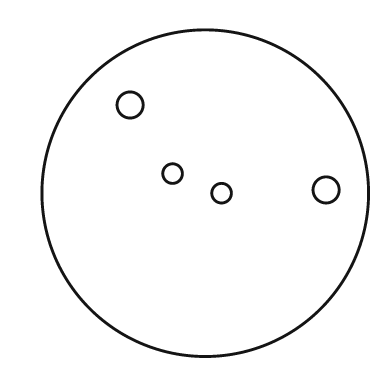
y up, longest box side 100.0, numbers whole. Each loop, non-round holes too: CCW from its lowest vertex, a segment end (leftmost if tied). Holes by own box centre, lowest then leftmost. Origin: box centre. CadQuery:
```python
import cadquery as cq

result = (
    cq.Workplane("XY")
    .moveTo(0.0, 0.0)
    .circle(50.0)
    .moveTo(5.0, 0.0)
    .circle(3.0)
    .moveTo(37.0, 1.0)
    .circle(4.0)
    .moveTo(-10.0, 6.0)
    .circle(3.0)
    .moveTo(-23.0, 27.0)
    .circle(4.0)
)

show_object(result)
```